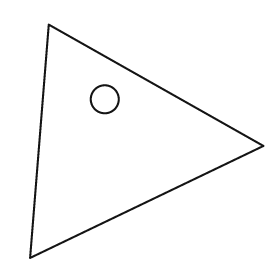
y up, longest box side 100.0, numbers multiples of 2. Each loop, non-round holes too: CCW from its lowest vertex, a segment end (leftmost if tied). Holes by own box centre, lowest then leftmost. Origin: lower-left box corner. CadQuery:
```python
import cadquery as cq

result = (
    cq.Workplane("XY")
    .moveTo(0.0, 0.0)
    .lineTo(100.0, 48.0)
    .lineTo(8.0, 100.0)
    .close()
    .moveTo(32.0, 68.0)
    .circle(6.0)
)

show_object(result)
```